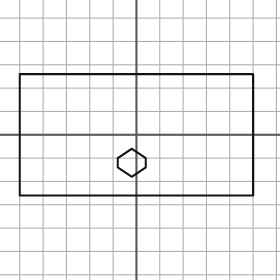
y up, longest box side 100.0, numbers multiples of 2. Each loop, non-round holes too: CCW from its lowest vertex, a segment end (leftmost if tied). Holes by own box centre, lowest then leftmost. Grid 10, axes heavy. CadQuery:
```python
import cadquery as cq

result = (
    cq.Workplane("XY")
    .moveTo(-50.0, -26.0)
    .lineTo(50.0, -26.0)
    .lineTo(50.0, 26.0)
    .lineTo(-50.0, 26.0)
    .close()
    .moveTo(-2.0, -18.0)
    .lineTo(4.0, -14.0)
    .lineTo(4.0, -10.0)
    .lineTo(-2.0, -6.0)
    .lineTo(-8.0, -10.0)
    .lineTo(-8.0, -14.0)
    .close()
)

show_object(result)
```